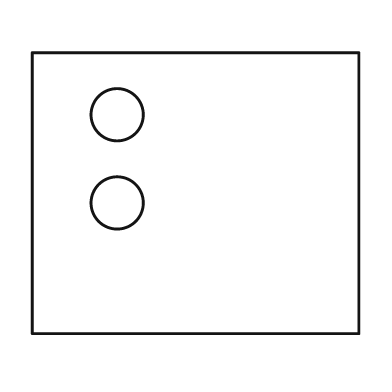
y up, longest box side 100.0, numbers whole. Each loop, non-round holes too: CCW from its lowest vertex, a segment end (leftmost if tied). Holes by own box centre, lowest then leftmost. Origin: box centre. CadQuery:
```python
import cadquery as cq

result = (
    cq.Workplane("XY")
    .moveTo(-50.0, -43.0)
    .lineTo(50.0, -43.0)
    .lineTo(50.0, 43.0)
    .lineTo(-50.0, 43.0)
    .close()
    .moveTo(-24.0, -3.0)
    .circle(8.0)
    .moveTo(-24.0, 24.0)
    .circle(8.0)
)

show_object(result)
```